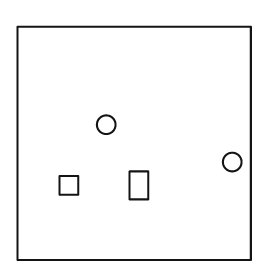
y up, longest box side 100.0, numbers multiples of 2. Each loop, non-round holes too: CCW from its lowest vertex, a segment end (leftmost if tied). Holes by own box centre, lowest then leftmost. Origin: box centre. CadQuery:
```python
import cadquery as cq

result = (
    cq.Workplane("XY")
    .moveTo(-50.0, -50.0)
    .lineTo(50.0, -50.0)
    .lineTo(50.0, 50.0)
    .lineTo(-50.0, 50.0)
    .close()
    .moveTo(-32.0, -22.0)
    .lineTo(-24.0, -22.0)
    .lineTo(-24.0, -14.0)
    .lineTo(-32.0, -14.0)
    .close()
    .moveTo(-2.0, -24.0)
    .lineTo(6.0, -24.0)
    .lineTo(6.0, -12.0)
    .lineTo(-2.0, -12.0)
    .close()
    .moveTo(42.0, -8.0)
    .circle(4.0)
    .moveTo(-12.0, 8.0)
    .circle(4.0)
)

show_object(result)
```